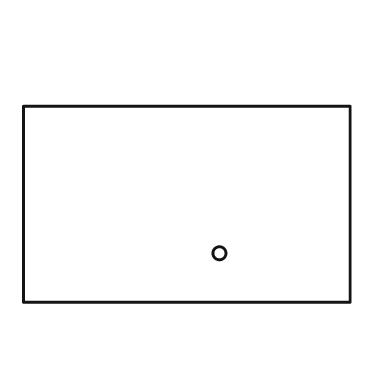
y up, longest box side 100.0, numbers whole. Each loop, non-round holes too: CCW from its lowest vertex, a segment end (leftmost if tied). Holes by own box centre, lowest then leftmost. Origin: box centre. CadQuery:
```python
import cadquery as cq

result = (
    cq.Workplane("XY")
    .moveTo(-50.0, -30.0)
    .lineTo(50.0, -30.0)
    .lineTo(50.0, 30.0)
    .lineTo(-50.0, 30.0)
    .close()
    .moveTo(10.0, -15.0)
    .circle(2.0)
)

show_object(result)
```